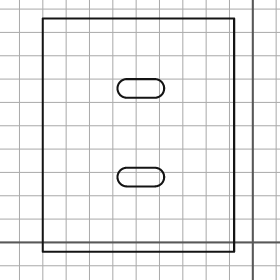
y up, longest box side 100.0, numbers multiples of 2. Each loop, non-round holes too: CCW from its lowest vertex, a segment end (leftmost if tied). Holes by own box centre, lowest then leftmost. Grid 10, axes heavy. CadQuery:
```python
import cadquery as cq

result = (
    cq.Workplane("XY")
    .moveTo(-90.0, -4.0)
    .lineTo(-8.0, -4.0)
    .lineTo(-8.0, 96.0)
    .lineTo(-90.0, 96.0)
    .close()
    .moveTo(-54.0, 24.0)
    .lineTo(-42.0, 24.0)
    .threePointArc((-38.0, 28.0), (-42.0, 32.0))
    .lineTo(-54.0, 32.0)
    .threePointArc((-58.0, 28.0), (-54.0, 24.0))
    .close()
    .moveTo(-54.0, 62.0)
    .lineTo(-42.0, 62.0)
    .threePointArc((-38.0, 66.0), (-42.0, 70.0))
    .lineTo(-54.0, 70.0)
    .threePointArc((-58.0, 66.0), (-54.0, 62.0))
    .close()
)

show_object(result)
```